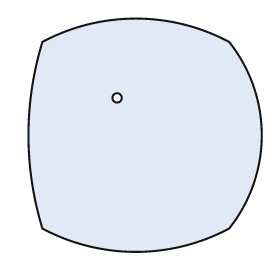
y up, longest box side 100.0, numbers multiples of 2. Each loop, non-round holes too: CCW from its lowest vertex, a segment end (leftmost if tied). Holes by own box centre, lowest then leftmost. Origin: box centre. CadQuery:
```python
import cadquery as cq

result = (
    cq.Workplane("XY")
    .moveTo(-44.0, -40.0)
    .threePointArc((-4.0, -50.0), (36.0, -40.0))
    .threePointArc((50.0, 0.0), (36.0, 40.0))
    .threePointArc((-4.0, 50.0), (-44.0, 40.0))
    .threePointArc((-50.0, 0.0), (-44.0, -40.0))
    .close()
    .moveTo(-12.0, 16.0)
    .circle(2.0)
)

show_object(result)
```